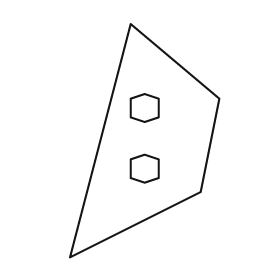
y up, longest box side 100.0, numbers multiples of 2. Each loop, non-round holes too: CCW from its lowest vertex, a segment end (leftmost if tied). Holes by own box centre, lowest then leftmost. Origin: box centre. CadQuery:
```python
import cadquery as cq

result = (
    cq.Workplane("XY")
    .moveTo(-32.0, -50.0)
    .lineTo(24.0, -22.0)
    .lineTo(32.0, 18.0)
    .lineTo(-6.0, 50.0)
    .close()
    .moveTo(0.0, -18.0)
    .lineTo(6.0, -16.0)
    .lineTo(6.0, -8.0)
    .lineTo(0.0, -6.0)
    .lineTo(-6.0, -8.0)
    .lineTo(-6.0, -16.0)
    .close()
    .moveTo(0.0, 8.0)
    .lineTo(6.0, 10.0)
    .lineTo(6.0, 18.0)
    .lineTo(0.0, 20.0)
    .lineTo(-6.0, 18.0)
    .lineTo(-6.0, 10.0)
    .close()
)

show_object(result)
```